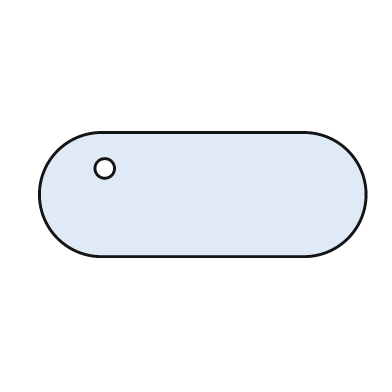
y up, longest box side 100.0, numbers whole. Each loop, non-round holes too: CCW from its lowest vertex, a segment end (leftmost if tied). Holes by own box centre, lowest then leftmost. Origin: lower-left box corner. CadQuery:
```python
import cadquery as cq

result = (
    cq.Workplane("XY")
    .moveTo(19.0, 0.0)
    .lineTo(81.0, 0.0)
    .threePointArc((100.0, 19.0), (81.0, 38.0))
    .lineTo(19.0, 38.0)
    .threePointArc((0.0, 19.0), (19.0, 0.0))
    .close()
    .moveTo(20.0, 27.0)
    .circle(3.0)
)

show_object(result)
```